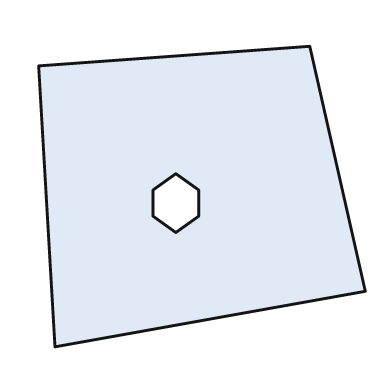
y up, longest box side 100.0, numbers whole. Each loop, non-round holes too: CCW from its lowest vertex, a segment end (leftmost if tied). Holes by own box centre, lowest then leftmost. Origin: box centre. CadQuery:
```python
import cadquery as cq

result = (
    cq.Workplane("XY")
    .moveTo(-45.0, -46.0)
    .lineTo(50.0, -29.0)
    .lineTo(33.0, 46.0)
    .lineTo(-50.0, 40.0)
    .close()
    .moveTo(-8.0, -11.0)
    .lineTo(-1.0, -6.0)
    .lineTo(-1.0, 2.0)
    .lineTo(-8.0, 7.0)
    .lineTo(-15.0, 2.0)
    .lineTo(-15.0, -6.0)
    .close()
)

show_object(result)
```